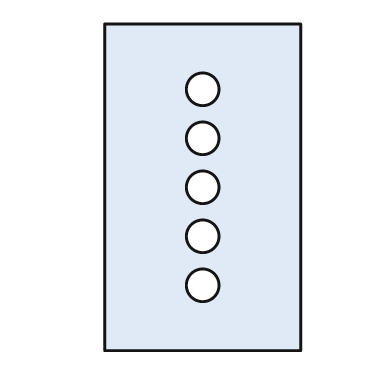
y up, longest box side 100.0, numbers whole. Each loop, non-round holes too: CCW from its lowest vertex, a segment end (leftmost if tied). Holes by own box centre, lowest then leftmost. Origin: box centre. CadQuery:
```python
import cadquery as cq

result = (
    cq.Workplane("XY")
    .moveTo(-30.0, -50.0)
    .lineTo(30.0, -50.0)
    .lineTo(30.0, 50.0)
    .lineTo(-30.0, 50.0)
    .close()
    .moveTo(0.0, -30.0)
    .circle(5.0)
    .moveTo(0.0, -15.0)
    .circle(5.0)
    .moveTo(0.0, 0.0)
    .circle(5.0)
    .moveTo(0.0, 15.0)
    .circle(5.0)
    .moveTo(0.0, 30.0)
    .circle(5.0)
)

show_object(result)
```